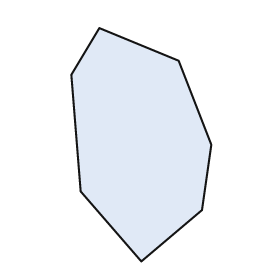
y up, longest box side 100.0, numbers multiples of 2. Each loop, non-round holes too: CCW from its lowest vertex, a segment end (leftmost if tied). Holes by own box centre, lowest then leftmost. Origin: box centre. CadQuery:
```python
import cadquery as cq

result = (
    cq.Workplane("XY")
    .moveTo(0.0, -50.0)
    .lineTo(26.0, -28.0)
    .lineTo(30.0, 0.0)
    .lineTo(16.0, 36.0)
    .lineTo(-18.0, 50.0)
    .lineTo(-30.0, 30.0)
    .lineTo(-26.0, -20.0)
    .close()
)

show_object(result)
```